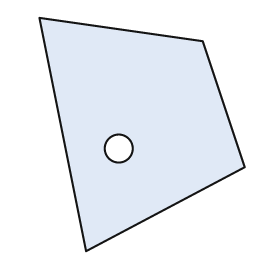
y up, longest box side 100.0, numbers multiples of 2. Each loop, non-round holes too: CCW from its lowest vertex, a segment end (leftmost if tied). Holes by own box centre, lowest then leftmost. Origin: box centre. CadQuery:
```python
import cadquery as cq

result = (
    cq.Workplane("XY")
    .moveTo(-24.0, -50.0)
    .lineTo(44.0, -14.0)
    .lineTo(26.0, 40.0)
    .lineTo(-44.0, 50.0)
    .close()
    .moveTo(-10.0, -6.0)
    .circle(6.0)
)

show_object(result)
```